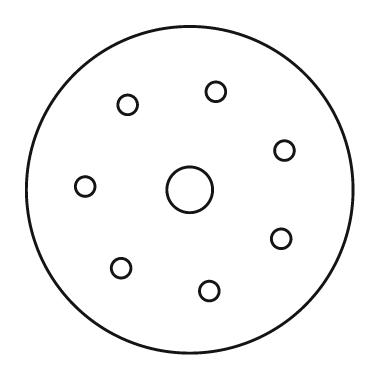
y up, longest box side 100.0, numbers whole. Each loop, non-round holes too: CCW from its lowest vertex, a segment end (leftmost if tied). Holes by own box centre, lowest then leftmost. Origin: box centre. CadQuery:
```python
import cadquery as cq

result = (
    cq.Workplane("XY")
    .moveTo(0.0, 0.0)
    .circle(50.0)
    .moveTo(6.0, -31.0)
    .circle(3.0)
    .moveTo(-21.0, -24.0)
    .circle(3.0)
    .moveTo(28.0, -15.0)
    .circle(3.0)
    .moveTo(0.0, 0.0)
    .circle(7.0)
    .moveTo(-32.0, 1.0)
    .circle(3.0)
    .moveTo(29.0, 12.0)
    .circle(3.0)
    .moveTo(-19.0, 26.0)
    .circle(3.0)
    .moveTo(8.0, 30.0)
    .circle(3.0)
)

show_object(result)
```